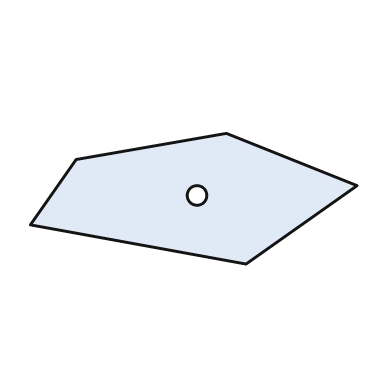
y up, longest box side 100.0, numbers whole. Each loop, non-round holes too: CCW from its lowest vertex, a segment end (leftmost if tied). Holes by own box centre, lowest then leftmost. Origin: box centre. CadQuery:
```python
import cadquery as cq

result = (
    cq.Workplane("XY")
    .moveTo(16.0, -20.0)
    .lineTo(50.0, 4.0)
    .lineTo(10.0, 20.0)
    .lineTo(-36.0, 12.0)
    .lineTo(-50.0, -8.0)
    .close()
    .moveTo(1.0, 1.0)
    .circle(3.0)
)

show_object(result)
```